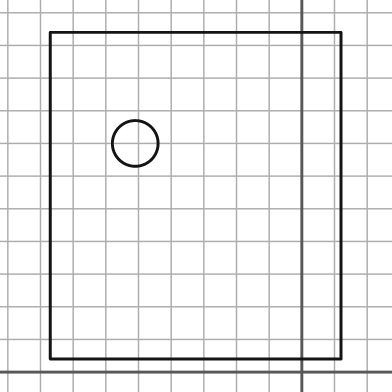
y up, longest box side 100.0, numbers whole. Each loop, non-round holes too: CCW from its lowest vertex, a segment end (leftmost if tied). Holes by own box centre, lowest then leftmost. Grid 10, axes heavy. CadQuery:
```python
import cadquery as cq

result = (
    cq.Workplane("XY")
    .moveTo(-77.0, 4.0)
    .lineTo(12.0, 4.0)
    .lineTo(12.0, 104.0)
    .lineTo(-77.0, 104.0)
    .close()
    .moveTo(-51.0, 70.0)
    .circle(7.0)
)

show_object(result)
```